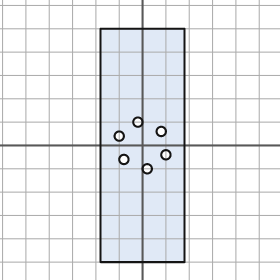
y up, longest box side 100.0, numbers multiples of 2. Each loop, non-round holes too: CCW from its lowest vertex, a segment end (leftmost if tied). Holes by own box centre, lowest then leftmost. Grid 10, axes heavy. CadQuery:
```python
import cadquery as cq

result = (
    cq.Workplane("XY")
    .moveTo(-18.0, -50.0)
    .lineTo(18.0, -50.0)
    .lineTo(18.0, 50.0)
    .lineTo(-18.0, 50.0)
    .close()
    .moveTo(2.0, -10.0)
    .circle(2.0)
    .moveTo(-8.0, -6.0)
    .circle(2.0)
    .moveTo(10.0, -4.0)
    .circle(2.0)
    .moveTo(-10.0, 4.0)
    .circle(2.0)
    .moveTo(8.0, 6.0)
    .circle(2.0)
    .moveTo(-2.0, 10.0)
    .circle(2.0)
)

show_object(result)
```